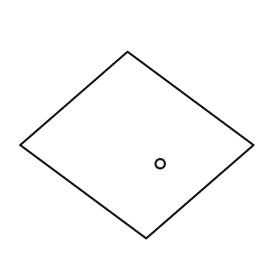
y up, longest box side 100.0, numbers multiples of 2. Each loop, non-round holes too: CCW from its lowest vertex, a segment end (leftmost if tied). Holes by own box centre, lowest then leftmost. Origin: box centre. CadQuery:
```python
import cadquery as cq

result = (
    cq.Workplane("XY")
    .moveTo(4.0, -40.0)
    .lineTo(50.0, 0.0)
    .lineTo(-4.0, 40.0)
    .lineTo(-50.0, 0.0)
    .close()
    .moveTo(10.0, -8.0)
    .circle(2.0)
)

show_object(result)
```